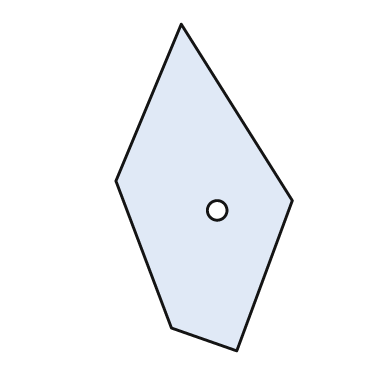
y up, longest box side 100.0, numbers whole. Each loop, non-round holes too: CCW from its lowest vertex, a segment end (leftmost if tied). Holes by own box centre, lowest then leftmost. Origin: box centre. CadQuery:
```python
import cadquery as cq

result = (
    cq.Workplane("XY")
    .moveTo(10.0, -50.0)
    .lineTo(27.0, -4.0)
    .lineTo(-7.0, 50.0)
    .lineTo(-27.0, 2.0)
    .lineTo(-10.0, -43.0)
    .close()
    .moveTo(4.0, -7.0)
    .circle(3.0)
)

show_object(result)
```